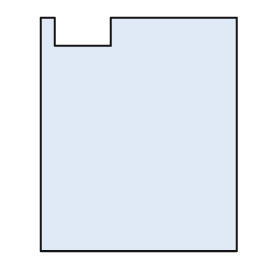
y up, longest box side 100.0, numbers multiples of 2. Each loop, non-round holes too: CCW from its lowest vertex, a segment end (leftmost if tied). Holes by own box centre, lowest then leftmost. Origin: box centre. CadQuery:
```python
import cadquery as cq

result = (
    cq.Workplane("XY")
    .moveTo(-42.0, -50.0)
    .lineTo(42.0, -50.0)
    .lineTo(42.0, 50.0)
    .lineTo(-12.0, 50.0)
    .lineTo(-12.0, 38.0)
    .lineTo(-36.0, 38.0)
    .lineTo(-36.0, 50.0)
    .lineTo(-42.0, 50.0)
    .close()
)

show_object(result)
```